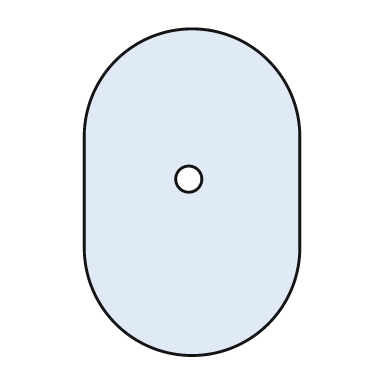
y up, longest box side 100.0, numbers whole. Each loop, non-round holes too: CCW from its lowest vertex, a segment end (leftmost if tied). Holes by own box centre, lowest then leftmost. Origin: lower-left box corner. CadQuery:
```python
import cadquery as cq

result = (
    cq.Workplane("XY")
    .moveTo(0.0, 33.0)
    .threePointArc((33.0, 0.0), (66.0, 33.0))
    .lineTo(66.0, 67.0)
    .threePointArc((33.0, 100.0), (0.0, 67.0))
    .close()
    .moveTo(32.0, 54.0)
    .circle(4.0)
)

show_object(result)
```